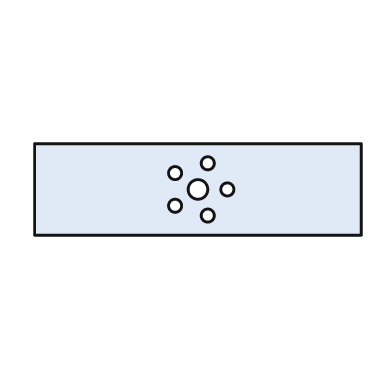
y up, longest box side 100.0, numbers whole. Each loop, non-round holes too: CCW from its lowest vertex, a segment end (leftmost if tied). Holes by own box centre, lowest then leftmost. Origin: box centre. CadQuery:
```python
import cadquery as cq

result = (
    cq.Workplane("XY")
    .moveTo(-50.0, -14.0)
    .lineTo(50.0, -14.0)
    .lineTo(50.0, 14.0)
    .lineTo(-50.0, 14.0)
    .close()
    .moveTo(3.0, -8.0)
    .circle(2.0)
    .moveTo(-7.0, -5.0)
    .circle(2.0)
    .moveTo(0.0, 0.0)
    .circle(3.0)
    .moveTo(9.0, 0.0)
    .circle(2.0)
    .moveTo(-7.0, 5.0)
    .circle(2.0)
    .moveTo(3.0, 8.0)
    .circle(2.0)
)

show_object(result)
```